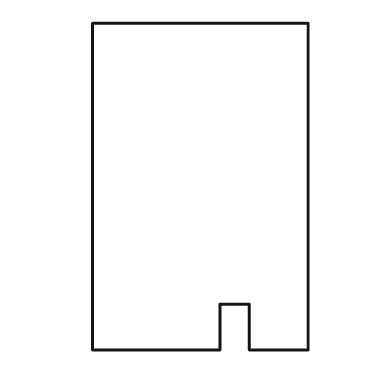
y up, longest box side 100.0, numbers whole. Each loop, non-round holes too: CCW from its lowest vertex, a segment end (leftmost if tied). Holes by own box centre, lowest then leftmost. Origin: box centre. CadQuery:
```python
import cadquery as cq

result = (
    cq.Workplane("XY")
    .moveTo(-33.0, -50.0)
    .lineTo(6.0, -50.0)
    .lineTo(6.0, -36.0)
    .lineTo(15.0, -36.0)
    .lineTo(15.0, -50.0)
    .lineTo(33.0, -50.0)
    .lineTo(33.0, 50.0)
    .lineTo(-33.0, 50.0)
    .close()
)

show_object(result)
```